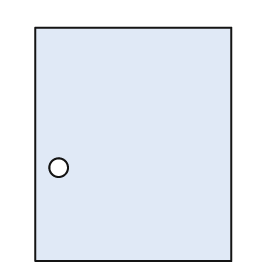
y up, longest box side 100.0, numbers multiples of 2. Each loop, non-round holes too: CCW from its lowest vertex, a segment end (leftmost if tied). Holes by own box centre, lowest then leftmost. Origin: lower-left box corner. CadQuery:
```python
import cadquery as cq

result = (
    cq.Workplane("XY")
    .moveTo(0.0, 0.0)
    .lineTo(84.0, 0.0)
    .lineTo(84.0, 100.0)
    .lineTo(0.0, 100.0)
    .close()
    .moveTo(10.0, 40.0)
    .circle(4.0)
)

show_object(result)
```